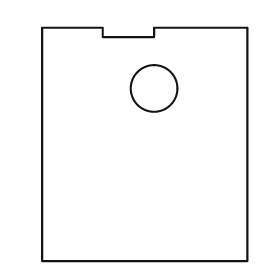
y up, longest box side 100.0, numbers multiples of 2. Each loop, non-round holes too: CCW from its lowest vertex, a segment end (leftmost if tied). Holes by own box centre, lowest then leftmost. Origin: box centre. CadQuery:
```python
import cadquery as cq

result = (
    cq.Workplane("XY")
    .moveTo(-44.0, -50.0)
    .lineTo(44.0, -50.0)
    .lineTo(44.0, 50.0)
    .lineTo(4.0, 50.0)
    .lineTo(4.0, 46.0)
    .lineTo(-18.0, 46.0)
    .lineTo(-18.0, 50.0)
    .lineTo(-44.0, 50.0)
    .close()
    .moveTo(4.0, 24.0)
    .circle(10.0)
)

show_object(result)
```